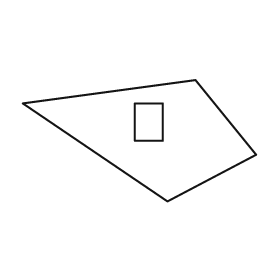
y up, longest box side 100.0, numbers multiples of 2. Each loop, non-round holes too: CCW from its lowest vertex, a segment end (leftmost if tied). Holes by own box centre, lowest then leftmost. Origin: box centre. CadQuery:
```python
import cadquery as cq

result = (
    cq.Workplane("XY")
    .moveTo(12.0, -26.0)
    .lineTo(50.0, -6.0)
    .lineTo(24.0, 26.0)
    .lineTo(-50.0, 16.0)
    .close()
    .moveTo(-2.0, 0.0)
    .lineTo(10.0, 0.0)
    .lineTo(10.0, 16.0)
    .lineTo(-2.0, 16.0)
    .close()
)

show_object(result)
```